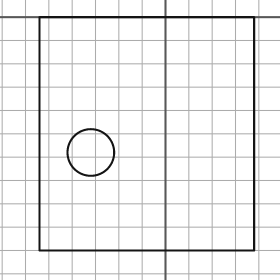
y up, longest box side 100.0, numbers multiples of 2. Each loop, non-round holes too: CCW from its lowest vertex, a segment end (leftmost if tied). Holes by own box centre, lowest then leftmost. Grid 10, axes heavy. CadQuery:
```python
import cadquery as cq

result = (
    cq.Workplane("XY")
    .moveTo(-54.0, -100.0)
    .lineTo(38.0, -100.0)
    .lineTo(38.0, 0.0)
    .lineTo(-54.0, 0.0)
    .close()
    .moveTo(-32.0, -58.0)
    .circle(10.0)
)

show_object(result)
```